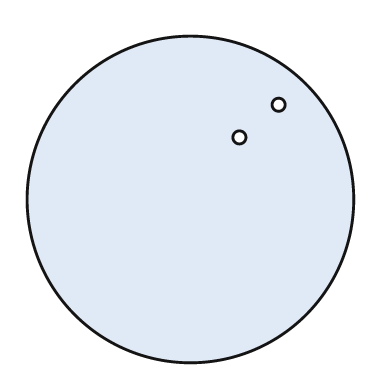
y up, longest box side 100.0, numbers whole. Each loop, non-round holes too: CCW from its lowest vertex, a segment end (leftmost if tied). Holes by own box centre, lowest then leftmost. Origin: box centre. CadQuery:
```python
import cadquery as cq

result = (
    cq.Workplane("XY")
    .moveTo(0.0, 0.0)
    .circle(50.0)
    .moveTo(15.0, 19.0)
    .circle(2.0)
    .moveTo(27.0, 29.0)
    .circle(2.0)
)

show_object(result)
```